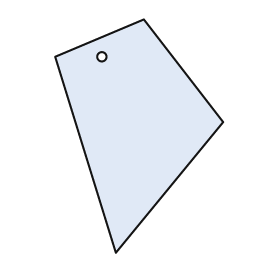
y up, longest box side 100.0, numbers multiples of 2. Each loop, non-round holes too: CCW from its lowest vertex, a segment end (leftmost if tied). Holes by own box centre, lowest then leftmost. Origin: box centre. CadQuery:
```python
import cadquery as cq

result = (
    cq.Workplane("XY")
    .moveTo(-10.0, -50.0)
    .lineTo(36.0, 6.0)
    .lineTo(2.0, 50.0)
    .lineTo(-36.0, 34.0)
    .close()
    .moveTo(-16.0, 34.0)
    .circle(2.0)
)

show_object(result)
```